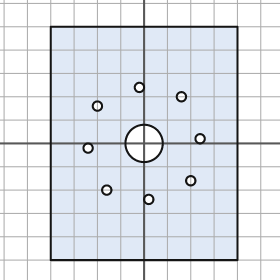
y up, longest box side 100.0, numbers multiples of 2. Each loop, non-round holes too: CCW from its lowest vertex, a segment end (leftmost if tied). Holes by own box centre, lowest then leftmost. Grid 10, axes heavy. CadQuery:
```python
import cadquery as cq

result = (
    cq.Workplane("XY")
    .moveTo(-40.0, -50.0)
    .lineTo(40.0, -50.0)
    .lineTo(40.0, 50.0)
    .lineTo(-40.0, 50.0)
    .close()
    .moveTo(2.0, -24.0)
    .circle(2.0)
    .moveTo(-16.0, -20.0)
    .circle(2.0)
    .moveTo(20.0, -16.0)
    .circle(2.0)
    .moveTo(-24.0, -2.0)
    .circle(2.0)
    .moveTo(0.0, 0.0)
    .circle(8.0)
    .moveTo(24.0, 2.0)
    .circle(2.0)
    .moveTo(-20.0, 16.0)
    .circle(2.0)
    .moveTo(16.0, 20.0)
    .circle(2.0)
    .moveTo(-2.0, 24.0)
    .circle(2.0)
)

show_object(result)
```